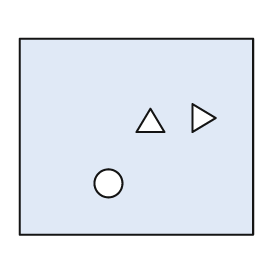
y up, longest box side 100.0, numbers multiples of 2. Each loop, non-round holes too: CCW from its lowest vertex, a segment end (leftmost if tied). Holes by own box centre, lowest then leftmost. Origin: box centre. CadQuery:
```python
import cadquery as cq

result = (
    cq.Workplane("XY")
    .moveTo(-50.0, -42.0)
    .lineTo(50.0, -42.0)
    .lineTo(50.0, 42.0)
    .lineTo(-50.0, 42.0)
    .close()
    .moveTo(-12.0, -20.0)
    .circle(6.0)
    .moveTo(0.0, 2.0)
    .lineTo(12.0, 2.0)
    .lineTo(6.0, 12.0)
    .close()
    .moveTo(24.0, 2.0)
    .lineTo(34.0, 8.0)
    .lineTo(24.0, 14.0)
    .close()
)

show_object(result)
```